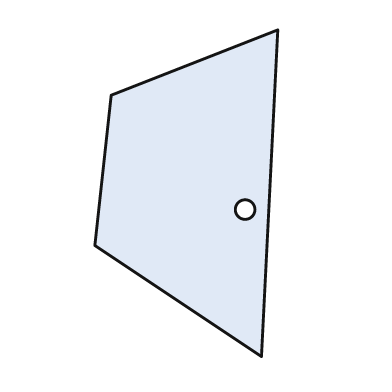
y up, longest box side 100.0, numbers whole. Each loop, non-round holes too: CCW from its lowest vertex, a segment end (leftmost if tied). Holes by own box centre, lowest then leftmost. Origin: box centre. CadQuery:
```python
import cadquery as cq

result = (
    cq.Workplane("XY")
    .moveTo(23.0, -50.0)
    .lineTo(28.0, 50.0)
    .lineTo(-23.0, 30.0)
    .lineTo(-28.0, -16.0)
    .close()
    .moveTo(18.0, -5.0)
    .circle(3.0)
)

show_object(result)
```